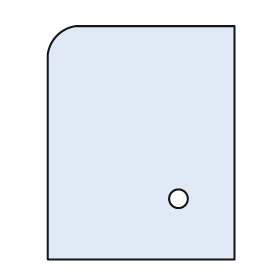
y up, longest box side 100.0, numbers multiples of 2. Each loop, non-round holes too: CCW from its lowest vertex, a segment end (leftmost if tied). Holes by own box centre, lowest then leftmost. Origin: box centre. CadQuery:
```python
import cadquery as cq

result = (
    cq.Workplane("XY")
    .moveTo(-40.0, -50.0)
    .lineTo(40.0, -50.0)
    .lineTo(40.0, 50.0)
    .lineTo(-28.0, 50.0)
    .threePointArc((-36.0, 46.0), (-40.0, 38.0))
    .close()
    .moveTo(16.0, -24.0)
    .circle(4.0)
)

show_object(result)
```